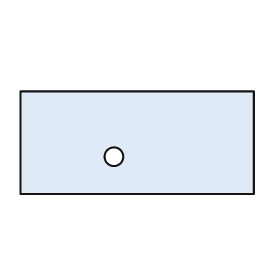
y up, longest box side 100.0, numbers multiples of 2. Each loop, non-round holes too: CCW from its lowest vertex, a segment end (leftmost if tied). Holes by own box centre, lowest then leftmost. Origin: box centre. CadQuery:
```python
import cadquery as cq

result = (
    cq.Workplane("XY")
    .moveTo(-50.0, -22.0)
    .lineTo(50.0, -22.0)
    .lineTo(50.0, 22.0)
    .lineTo(-50.0, 22.0)
    .close()
    .moveTo(-10.0, -6.0)
    .circle(4.0)
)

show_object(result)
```